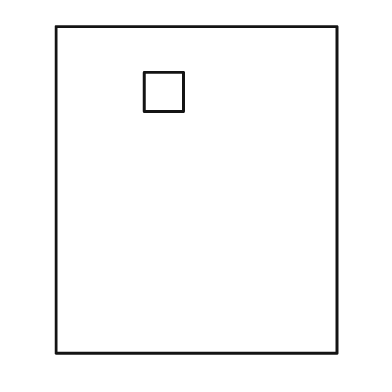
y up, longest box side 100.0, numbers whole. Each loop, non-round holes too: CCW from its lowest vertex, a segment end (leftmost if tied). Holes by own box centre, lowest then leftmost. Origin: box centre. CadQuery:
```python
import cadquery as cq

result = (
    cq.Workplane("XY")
    .moveTo(-43.0, -50.0)
    .lineTo(43.0, -50.0)
    .lineTo(43.0, 50.0)
    .lineTo(-43.0, 50.0)
    .close()
    .moveTo(-16.0, 24.0)
    .lineTo(-4.0, 24.0)
    .lineTo(-4.0, 36.0)
    .lineTo(-16.0, 36.0)
    .close()
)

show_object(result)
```